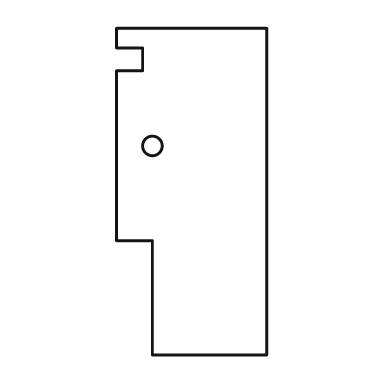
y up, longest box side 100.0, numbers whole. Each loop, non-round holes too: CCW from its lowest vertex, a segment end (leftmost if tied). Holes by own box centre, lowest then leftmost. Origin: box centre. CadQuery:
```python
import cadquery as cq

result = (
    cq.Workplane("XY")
    .moveTo(-12.0, -50.0)
    .lineTo(23.0, -50.0)
    .lineTo(23.0, 50.0)
    .lineTo(-23.0, 50.0)
    .lineTo(-23.0, 44.0)
    .lineTo(-15.0, 44.0)
    .lineTo(-15.0, 37.0)
    .lineTo(-23.0, 37.0)
    .lineTo(-23.0, -15.0)
    .lineTo(-12.0, -15.0)
    .close()
    .moveTo(-12.0, 14.0)
    .circle(3.0)
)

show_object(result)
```